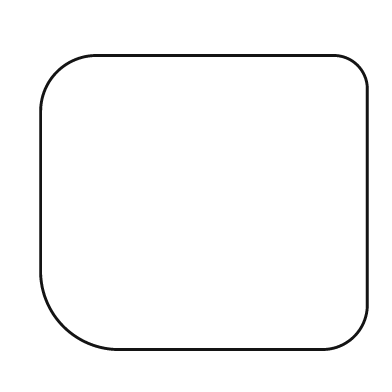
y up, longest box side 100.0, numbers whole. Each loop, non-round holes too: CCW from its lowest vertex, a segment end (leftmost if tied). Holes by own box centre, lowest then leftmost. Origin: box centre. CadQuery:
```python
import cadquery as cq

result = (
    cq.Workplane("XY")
    .moveTo(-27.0, -45.0)
    .lineTo(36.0, -45.0)
    .threePointArc((46.0, -41.0), (50.0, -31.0))
    .lineTo(50.0, 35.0)
    .threePointArc((47.0, 42.0), (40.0, 45.0))
    .lineTo(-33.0, 45.0)
    .threePointArc((-45.0, 40.0), (-50.0, 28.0))
    .lineTo(-50.0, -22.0)
    .threePointArc((-43.0, -38.0), (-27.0, -45.0))
    .close()
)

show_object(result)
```